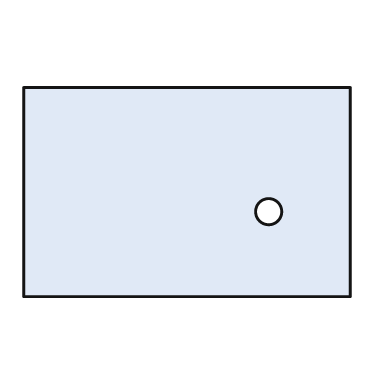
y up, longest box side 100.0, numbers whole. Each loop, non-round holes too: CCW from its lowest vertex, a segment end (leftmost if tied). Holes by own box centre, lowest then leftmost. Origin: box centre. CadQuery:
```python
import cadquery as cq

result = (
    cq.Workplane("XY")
    .moveTo(-50.0, -32.0)
    .lineTo(50.0, -32.0)
    .lineTo(50.0, 32.0)
    .lineTo(-50.0, 32.0)
    .close()
    .moveTo(25.0, -6.0)
    .circle(4.0)
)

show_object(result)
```